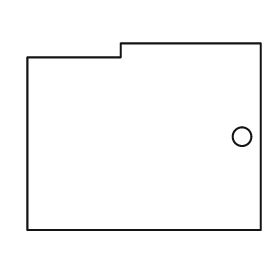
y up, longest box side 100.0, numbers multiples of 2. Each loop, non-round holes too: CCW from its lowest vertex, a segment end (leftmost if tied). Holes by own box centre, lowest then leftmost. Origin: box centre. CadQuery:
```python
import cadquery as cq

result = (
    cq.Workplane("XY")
    .moveTo(-50.0, -40.0)
    .lineTo(50.0, -40.0)
    .lineTo(50.0, 40.0)
    .lineTo(-10.0, 40.0)
    .lineTo(-10.0, 34.0)
    .lineTo(-50.0, 34.0)
    .close()
    .moveTo(42.0, 0.0)
    .circle(4.0)
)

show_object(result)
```